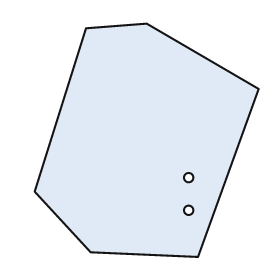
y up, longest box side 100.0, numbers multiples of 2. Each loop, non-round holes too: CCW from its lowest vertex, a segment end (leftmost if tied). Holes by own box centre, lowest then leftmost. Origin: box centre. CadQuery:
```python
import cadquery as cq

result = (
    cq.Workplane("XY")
    .moveTo(22.0, -50.0)
    .lineTo(48.0, 22.0)
    .lineTo(0.0, 50.0)
    .lineTo(-26.0, 48.0)
    .lineTo(-48.0, -22.0)
    .lineTo(-24.0, -48.0)
    .close()
    .moveTo(18.0, -30.0)
    .circle(2.0)
    .moveTo(18.0, -16.0)
    .circle(2.0)
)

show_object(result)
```